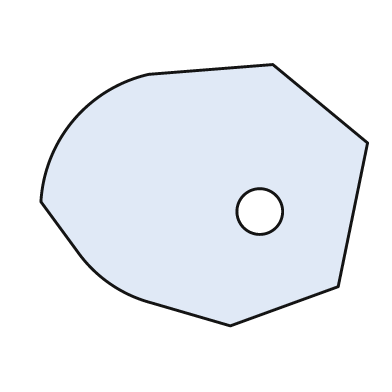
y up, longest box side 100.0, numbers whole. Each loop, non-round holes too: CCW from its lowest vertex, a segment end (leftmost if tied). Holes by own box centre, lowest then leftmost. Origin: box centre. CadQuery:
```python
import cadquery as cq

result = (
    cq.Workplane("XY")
    .moveTo(8.0, -40.0)
    .lineTo(41.0, -28.0)
    .lineTo(50.0, 16.0)
    .lineTo(21.0, 40.0)
    .lineTo(-17.0, 37.0)
    .threePointArc((-40.0, 23.0), (-50.0, -2.0))
    .lineTo(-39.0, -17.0)
    .threePointArc((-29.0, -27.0), (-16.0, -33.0))
    .close()
    .moveTo(17.0, -5.0)
    .circle(7.0)
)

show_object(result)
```